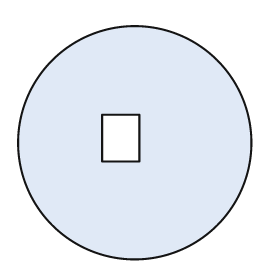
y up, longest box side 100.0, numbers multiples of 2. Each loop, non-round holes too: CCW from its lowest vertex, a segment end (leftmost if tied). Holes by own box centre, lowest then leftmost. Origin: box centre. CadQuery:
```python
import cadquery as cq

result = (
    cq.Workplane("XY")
    .moveTo(0.0, 0.0)
    .circle(50.0)
    .moveTo(-14.0, -8.0)
    .lineTo(2.0, -8.0)
    .lineTo(2.0, 12.0)
    .lineTo(-14.0, 12.0)
    .close()
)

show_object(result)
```